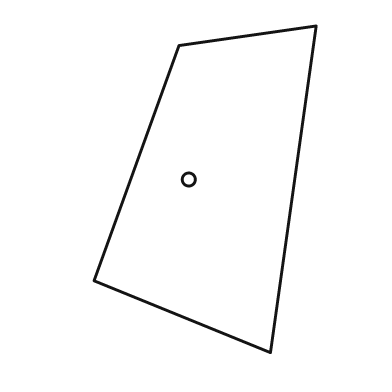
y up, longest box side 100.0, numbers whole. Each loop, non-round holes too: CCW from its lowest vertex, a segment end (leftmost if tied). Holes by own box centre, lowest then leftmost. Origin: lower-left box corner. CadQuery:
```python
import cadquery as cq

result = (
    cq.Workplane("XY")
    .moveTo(54.0, 0.0)
    .lineTo(68.0, 100.0)
    .lineTo(26.0, 94.0)
    .lineTo(0.0, 22.0)
    .close()
    .moveTo(29.0, 53.0)
    .circle(2.0)
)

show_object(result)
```